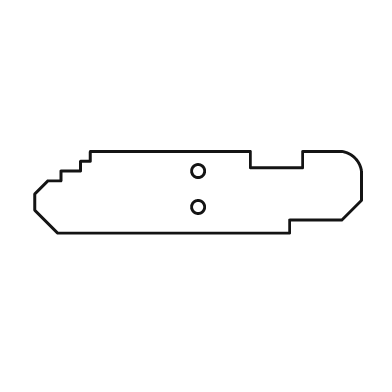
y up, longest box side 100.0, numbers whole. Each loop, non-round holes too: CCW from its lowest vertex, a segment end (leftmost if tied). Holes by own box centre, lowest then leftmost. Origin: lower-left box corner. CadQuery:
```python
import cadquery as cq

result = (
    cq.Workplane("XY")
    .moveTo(7.0, 0.0)
    .lineTo(78.0, 0.0)
    .lineTo(78.0, 4.0)
    .lineTo(94.0, 4.0)
    .lineTo(100.0, 10.0)
    .lineTo(100.0, 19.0)
    .threePointArc((98.0, 23.0), (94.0, 25.0))
    .lineTo(82.0, 25.0)
    .lineTo(82.0, 20.0)
    .lineTo(66.0, 20.0)
    .lineTo(66.0, 25.0)
    .lineTo(17.0, 25.0)
    .lineTo(17.0, 22.0)
    .lineTo(14.0, 22.0)
    .lineTo(14.0, 19.0)
    .lineTo(8.0, 19.0)
    .lineTo(8.0, 16.0)
    .lineTo(4.0, 16.0)
    .lineTo(0.0, 12.0)
    .lineTo(0.0, 7.0)
    .close()
    .moveTo(50.0, 8.0)
    .circle(2.0)
    .moveTo(50.0, 19.0)
    .circle(2.0)
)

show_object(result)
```